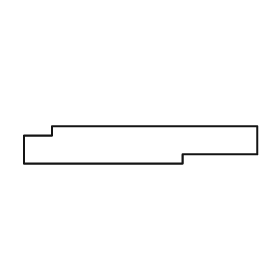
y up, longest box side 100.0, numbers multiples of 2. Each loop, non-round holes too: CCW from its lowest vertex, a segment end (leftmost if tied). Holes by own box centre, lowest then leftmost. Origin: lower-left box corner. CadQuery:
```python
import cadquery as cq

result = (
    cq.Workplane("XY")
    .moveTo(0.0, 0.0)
    .lineTo(68.0, 0.0)
    .lineTo(68.0, 4.0)
    .lineTo(100.0, 4.0)
    .lineTo(100.0, 16.0)
    .lineTo(12.0, 16.0)
    .lineTo(12.0, 12.0)
    .lineTo(0.0, 12.0)
    .close()
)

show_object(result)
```